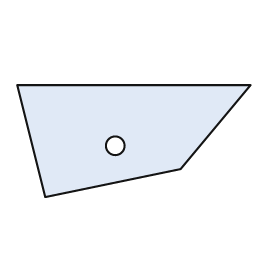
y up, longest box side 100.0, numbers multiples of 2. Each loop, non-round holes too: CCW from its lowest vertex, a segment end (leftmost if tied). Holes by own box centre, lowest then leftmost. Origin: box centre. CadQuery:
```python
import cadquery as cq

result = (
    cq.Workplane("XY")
    .moveTo(-38.0, -24.0)
    .lineTo(20.0, -12.0)
    .lineTo(50.0, 24.0)
    .lineTo(-50.0, 24.0)
    .close()
    .moveTo(-8.0, -2.0)
    .circle(4.0)
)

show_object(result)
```